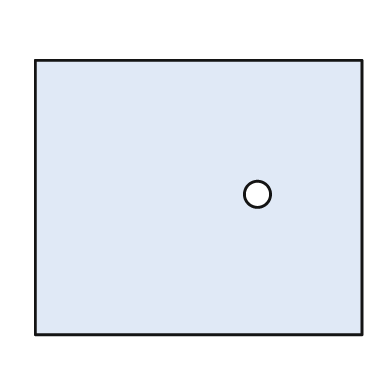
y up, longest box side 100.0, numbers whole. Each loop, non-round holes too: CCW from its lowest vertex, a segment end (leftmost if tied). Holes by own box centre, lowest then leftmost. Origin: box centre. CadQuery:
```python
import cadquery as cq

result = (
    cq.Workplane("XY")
    .moveTo(-50.0, -42.0)
    .lineTo(50.0, -42.0)
    .lineTo(50.0, 42.0)
    .lineTo(-50.0, 42.0)
    .close()
    .moveTo(18.0, 1.0)
    .circle(4.0)
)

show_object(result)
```